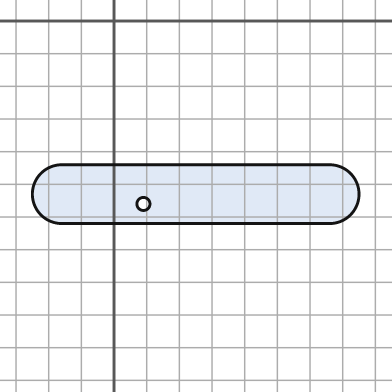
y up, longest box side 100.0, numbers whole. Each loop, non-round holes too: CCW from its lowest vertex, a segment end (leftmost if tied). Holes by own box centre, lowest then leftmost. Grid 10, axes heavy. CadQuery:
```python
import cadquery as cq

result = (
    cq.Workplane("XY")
    .moveTo(-16.0, -62.0)
    .lineTo(66.0, -62.0)
    .threePointArc((75.0, -53.0), (66.0, -44.0))
    .lineTo(-16.0, -44.0)
    .threePointArc((-25.0, -53.0), (-16.0, -62.0))
    .close()
    .moveTo(9.0, -56.0)
    .circle(2.0)
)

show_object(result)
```